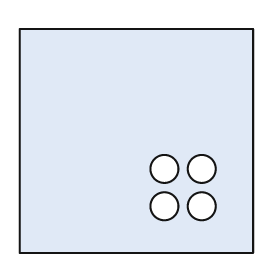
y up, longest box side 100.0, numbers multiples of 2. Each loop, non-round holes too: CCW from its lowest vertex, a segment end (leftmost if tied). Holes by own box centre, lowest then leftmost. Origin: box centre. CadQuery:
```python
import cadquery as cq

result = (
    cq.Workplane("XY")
    .moveTo(-50.0, -48.0)
    .lineTo(50.0, -48.0)
    .lineTo(50.0, 48.0)
    .lineTo(-50.0, 48.0)
    .close()
    .moveTo(12.0, -28.0)
    .circle(6.0)
    .moveTo(28.0, -28.0)
    .circle(6.0)
    .moveTo(12.0, -12.0)
    .circle(6.0)
    .moveTo(28.0, -12.0)
    .circle(6.0)
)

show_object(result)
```